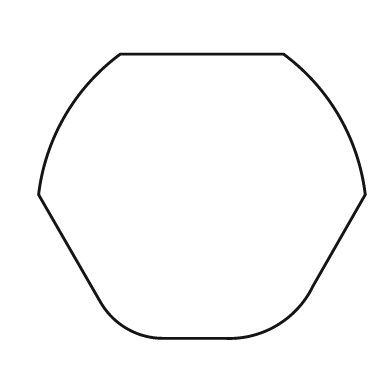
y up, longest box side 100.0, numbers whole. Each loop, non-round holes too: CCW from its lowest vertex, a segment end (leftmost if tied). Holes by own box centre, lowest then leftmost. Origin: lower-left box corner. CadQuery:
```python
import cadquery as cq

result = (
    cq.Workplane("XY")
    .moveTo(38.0, 0.0)
    .lineTo(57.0, 0.0)
    .threePointArc((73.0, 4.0), (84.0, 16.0))
    .lineTo(100.0, 44.0)
    .threePointArc((92.0, 68.0), (75.0, 87.0))
    .lineTo(25.0, 87.0)
    .threePointArc((8.0, 68.0), (0.0, 44.0))
    .lineTo(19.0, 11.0)
    .threePointArc((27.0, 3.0), (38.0, 0.0))
    .close()
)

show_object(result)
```